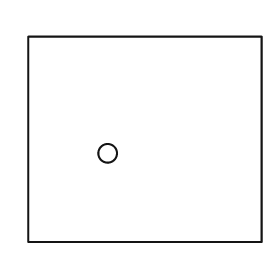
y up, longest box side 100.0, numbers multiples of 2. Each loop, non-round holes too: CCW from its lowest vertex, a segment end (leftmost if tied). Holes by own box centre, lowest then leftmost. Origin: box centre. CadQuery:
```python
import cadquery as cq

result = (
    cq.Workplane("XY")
    .moveTo(-50.0, -44.0)
    .lineTo(50.0, -44.0)
    .lineTo(50.0, 44.0)
    .lineTo(-50.0, 44.0)
    .close()
    .moveTo(-16.0, -6.0)
    .circle(4.0)
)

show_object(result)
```